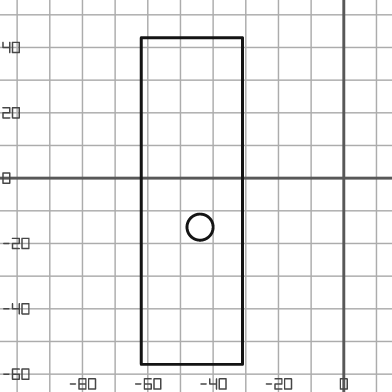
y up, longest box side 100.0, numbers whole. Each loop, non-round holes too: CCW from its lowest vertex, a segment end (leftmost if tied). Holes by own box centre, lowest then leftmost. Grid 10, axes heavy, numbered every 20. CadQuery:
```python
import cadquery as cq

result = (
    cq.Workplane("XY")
    .moveTo(-62.0, -57.0)
    .lineTo(-31.0, -57.0)
    .lineTo(-31.0, 43.0)
    .lineTo(-62.0, 43.0)
    .close()
    .moveTo(-44.0, -15.0)
    .circle(4.0)
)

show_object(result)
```